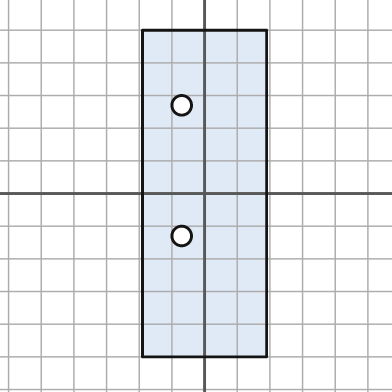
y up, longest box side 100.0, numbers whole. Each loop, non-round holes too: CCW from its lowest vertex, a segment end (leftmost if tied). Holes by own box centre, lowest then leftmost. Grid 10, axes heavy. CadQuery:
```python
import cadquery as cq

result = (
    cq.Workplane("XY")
    .moveTo(-19.0, -50.0)
    .lineTo(19.0, -50.0)
    .lineTo(19.0, 50.0)
    .lineTo(-19.0, 50.0)
    .close()
    .moveTo(-7.0, -13.0)
    .circle(3.0)
    .moveTo(-7.0, 27.0)
    .circle(3.0)
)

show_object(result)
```